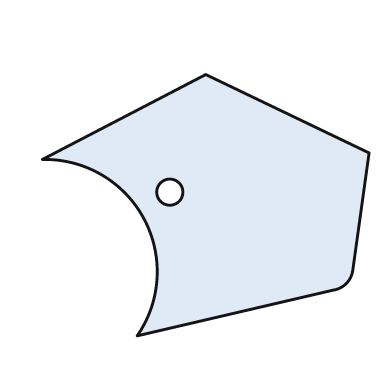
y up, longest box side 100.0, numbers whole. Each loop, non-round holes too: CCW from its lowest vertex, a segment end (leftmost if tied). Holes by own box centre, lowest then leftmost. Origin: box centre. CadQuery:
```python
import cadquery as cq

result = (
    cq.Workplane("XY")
    .moveTo(-21.0, -40.0)
    .lineTo(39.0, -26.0)
    .threePointArc((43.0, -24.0), (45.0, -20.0))
    .lineTo(50.0, 16.0)
    .lineTo(0.0, 40.0)
    .lineTo(-50.0, 14.0)
    .threePointArc((-19.0, -4.0), (-21.0, -40.0))
    .close()
    .moveTo(-11.0, 4.0)
    .circle(4.0)
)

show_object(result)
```